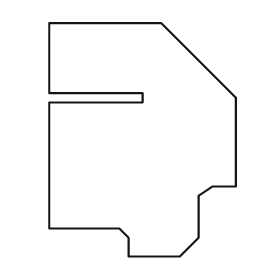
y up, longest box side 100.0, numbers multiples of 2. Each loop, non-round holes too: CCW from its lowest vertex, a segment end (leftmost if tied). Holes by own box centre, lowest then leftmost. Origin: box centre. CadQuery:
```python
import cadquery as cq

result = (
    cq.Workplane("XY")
    .moveTo(-6.0, -50.0)
    .lineTo(16.0, -50.0)
    .lineTo(24.0, -42.0)
    .lineTo(24.0, -24.0)
    .lineTo(30.0, -20.0)
    .lineTo(40.0, -20.0)
    .lineTo(40.0, 18.0)
    .lineTo(8.0, 50.0)
    .lineTo(-40.0, 50.0)
    .lineTo(-40.0, 20.0)
    .lineTo(0.0, 20.0)
    .lineTo(0.0, 16.0)
    .lineTo(-40.0, 16.0)
    .lineTo(-40.0, -38.0)
    .lineTo(-10.0, -38.0)
    .lineTo(-6.0, -42.0)
    .close()
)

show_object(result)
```